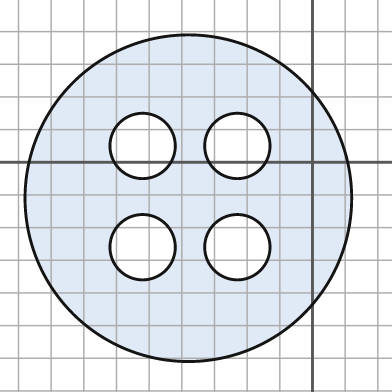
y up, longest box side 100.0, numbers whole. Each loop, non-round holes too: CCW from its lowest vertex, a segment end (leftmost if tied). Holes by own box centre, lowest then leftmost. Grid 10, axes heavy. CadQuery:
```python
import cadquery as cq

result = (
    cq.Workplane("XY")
    .moveTo(-38.0, -11.0)
    .circle(50.0)
    .moveTo(-52.0, -26.0)
    .circle(10.0)
    .moveTo(-23.0, -26.0)
    .circle(10.0)
    .moveTo(-52.0, 5.0)
    .circle(10.0)
    .moveTo(-23.0, 5.0)
    .circle(10.0)
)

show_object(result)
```